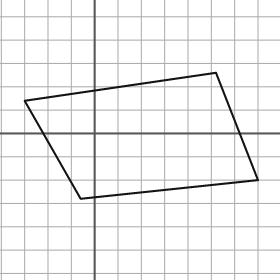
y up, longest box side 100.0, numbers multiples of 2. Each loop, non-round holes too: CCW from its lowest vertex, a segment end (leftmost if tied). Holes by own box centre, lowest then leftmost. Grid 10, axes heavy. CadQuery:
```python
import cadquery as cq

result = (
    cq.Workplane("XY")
    .moveTo(-6.0, -28.0)
    .lineTo(70.0, -20.0)
    .lineTo(52.0, 26.0)
    .lineTo(-30.0, 14.0)
    .close()
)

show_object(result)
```